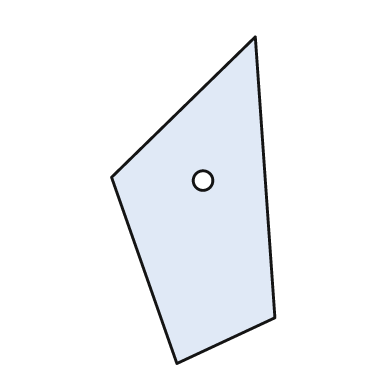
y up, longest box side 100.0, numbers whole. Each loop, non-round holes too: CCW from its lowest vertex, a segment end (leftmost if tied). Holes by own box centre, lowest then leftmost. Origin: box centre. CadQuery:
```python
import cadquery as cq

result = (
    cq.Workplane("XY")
    .moveTo(-5.0, -50.0)
    .lineTo(25.0, -36.0)
    .lineTo(19.0, 50.0)
    .lineTo(-25.0, 7.0)
    .close()
    .moveTo(3.0, 6.0)
    .circle(3.0)
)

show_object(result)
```